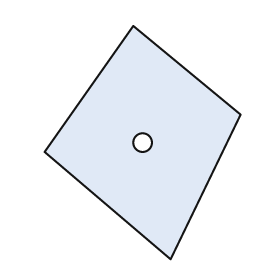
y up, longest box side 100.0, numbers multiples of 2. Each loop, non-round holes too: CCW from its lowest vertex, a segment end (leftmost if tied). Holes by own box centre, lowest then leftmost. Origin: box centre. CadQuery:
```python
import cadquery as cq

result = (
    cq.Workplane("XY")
    .moveTo(12.0, -50.0)
    .lineTo(42.0, 12.0)
    .lineTo(-4.0, 50.0)
    .lineTo(-42.0, -4.0)
    .close()
    .moveTo(0.0, 0.0)
    .circle(4.0)
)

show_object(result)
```